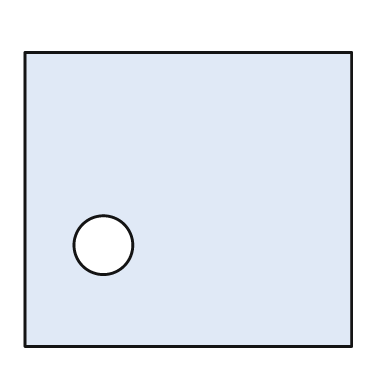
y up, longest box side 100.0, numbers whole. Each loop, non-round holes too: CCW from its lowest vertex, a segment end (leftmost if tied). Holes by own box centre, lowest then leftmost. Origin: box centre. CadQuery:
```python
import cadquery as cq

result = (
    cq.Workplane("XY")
    .moveTo(-50.0, -45.0)
    .lineTo(50.0, -45.0)
    .lineTo(50.0, 45.0)
    .lineTo(-50.0, 45.0)
    .close()
    .moveTo(-26.0, -14.0)
    .circle(9.0)
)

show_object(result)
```